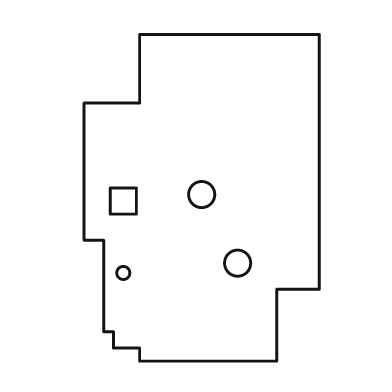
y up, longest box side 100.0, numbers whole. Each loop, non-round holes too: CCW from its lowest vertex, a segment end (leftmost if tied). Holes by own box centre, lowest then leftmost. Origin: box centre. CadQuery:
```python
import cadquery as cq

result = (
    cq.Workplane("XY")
    .moveTo(-19.0, -50.0)
    .lineTo(23.0, -50.0)
    .lineTo(23.0, -28.0)
    .lineTo(36.0, -28.0)
    .lineTo(36.0, 50.0)
    .lineTo(-19.0, 50.0)
    .lineTo(-19.0, 29.0)
    .lineTo(-36.0, 29.0)
    .lineTo(-36.0, -13.0)
    .lineTo(-30.0, -13.0)
    .lineTo(-30.0, -41.0)
    .lineTo(-27.0, -41.0)
    .lineTo(-27.0, -46.0)
    .lineTo(-19.0, -46.0)
    .close()
    .moveTo(-24.0, -23.0)
    .circle(2.0)
    .moveTo(11.0, -20.0)
    .circle(4.0)
    .moveTo(-28.0, -5.0)
    .lineTo(-20.0, -5.0)
    .lineTo(-20.0, 3.0)
    .lineTo(-28.0, 3.0)
    .close()
    .moveTo(0.0, 1.0)
    .circle(4.0)
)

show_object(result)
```